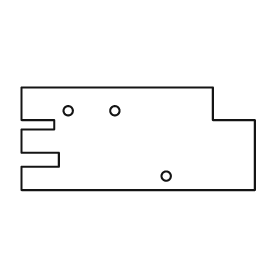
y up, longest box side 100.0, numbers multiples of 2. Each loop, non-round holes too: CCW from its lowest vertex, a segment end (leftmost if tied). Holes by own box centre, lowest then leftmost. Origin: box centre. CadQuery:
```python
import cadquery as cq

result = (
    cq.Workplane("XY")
    .moveTo(-50.0, -22.0)
    .lineTo(50.0, -22.0)
    .lineTo(50.0, 8.0)
    .lineTo(32.0, 8.0)
    .lineTo(32.0, 22.0)
    .lineTo(-50.0, 22.0)
    .lineTo(-50.0, 8.0)
    .lineTo(-36.0, 8.0)
    .lineTo(-36.0, 4.0)
    .lineTo(-50.0, 4.0)
    .lineTo(-50.0, -6.0)
    .lineTo(-34.0, -6.0)
    .lineTo(-34.0, -12.0)
    .lineTo(-50.0, -12.0)
    .close()
    .moveTo(12.0, -16.0)
    .circle(2.0)
    .moveTo(-30.0, 12.0)
    .circle(2.0)
    .moveTo(-10.0, 12.0)
    .circle(2.0)
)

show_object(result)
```